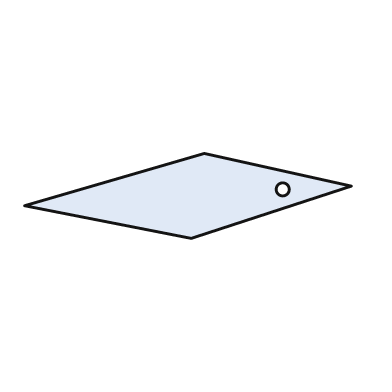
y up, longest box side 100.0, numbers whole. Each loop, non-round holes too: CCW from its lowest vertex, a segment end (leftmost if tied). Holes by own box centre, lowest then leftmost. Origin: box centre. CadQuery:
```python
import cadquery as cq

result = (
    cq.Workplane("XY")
    .moveTo(1.0, -13.0)
    .lineTo(50.0, 3.0)
    .lineTo(5.0, 13.0)
    .lineTo(-50.0, -3.0)
    .close()
    .moveTo(29.0, 2.0)
    .circle(2.0)
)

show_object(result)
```